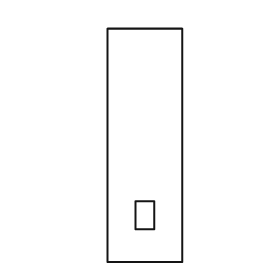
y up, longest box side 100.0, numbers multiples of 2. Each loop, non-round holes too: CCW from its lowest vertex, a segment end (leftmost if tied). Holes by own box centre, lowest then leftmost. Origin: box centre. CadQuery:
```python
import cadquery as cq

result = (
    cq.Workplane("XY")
    .moveTo(-16.0, -50.0)
    .lineTo(16.0, -50.0)
    .lineTo(16.0, 50.0)
    .lineTo(-16.0, 50.0)
    .close()
    .moveTo(-4.0, -36.0)
    .lineTo(4.0, -36.0)
    .lineTo(4.0, -24.0)
    .lineTo(-4.0, -24.0)
    .close()
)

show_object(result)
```